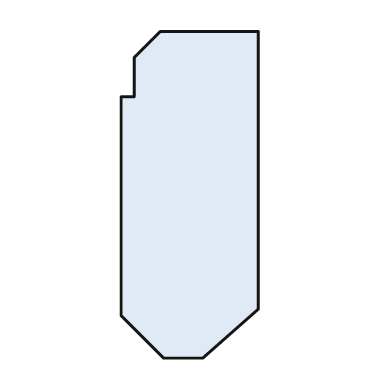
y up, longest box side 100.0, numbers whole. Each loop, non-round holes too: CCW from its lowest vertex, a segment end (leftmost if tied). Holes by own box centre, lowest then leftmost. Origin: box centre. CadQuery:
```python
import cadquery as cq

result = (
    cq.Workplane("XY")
    .moveTo(-8.0, -50.0)
    .lineTo(4.0, -50.0)
    .lineTo(21.0, -35.0)
    .lineTo(21.0, 50.0)
    .lineTo(-9.0, 50.0)
    .lineTo(-17.0, 42.0)
    .lineTo(-17.0, 30.0)
    .lineTo(-21.0, 30.0)
    .lineTo(-21.0, -37.0)
    .close()
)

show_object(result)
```